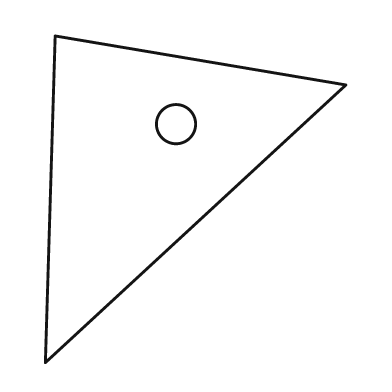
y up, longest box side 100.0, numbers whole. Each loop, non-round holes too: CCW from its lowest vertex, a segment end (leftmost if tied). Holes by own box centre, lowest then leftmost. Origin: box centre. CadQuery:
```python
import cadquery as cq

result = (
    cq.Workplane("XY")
    .moveTo(-46.0, -50.0)
    .lineTo(46.0, 35.0)
    .lineTo(-43.0, 50.0)
    .close()
    .moveTo(-6.0, 23.0)
    .circle(6.0)
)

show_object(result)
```